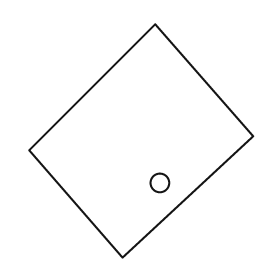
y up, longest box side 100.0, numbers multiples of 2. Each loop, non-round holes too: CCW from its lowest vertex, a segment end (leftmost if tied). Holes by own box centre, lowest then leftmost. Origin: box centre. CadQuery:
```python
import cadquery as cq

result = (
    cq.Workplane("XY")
    .moveTo(-8.0, -50.0)
    .lineTo(48.0, 2.0)
    .lineTo(6.0, 50.0)
    .lineTo(-48.0, -4.0)
    .close()
    .moveTo(8.0, -18.0)
    .circle(4.0)
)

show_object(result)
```